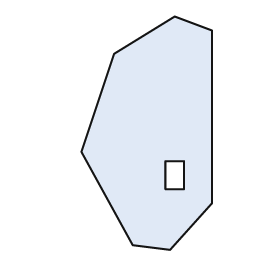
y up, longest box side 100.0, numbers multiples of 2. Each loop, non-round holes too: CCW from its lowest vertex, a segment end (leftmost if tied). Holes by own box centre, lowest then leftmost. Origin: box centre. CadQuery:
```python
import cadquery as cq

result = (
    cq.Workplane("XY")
    .moveTo(10.0, -50.0)
    .lineTo(28.0, -30.0)
    .lineTo(28.0, 44.0)
    .lineTo(12.0, 50.0)
    .lineTo(-14.0, 34.0)
    .lineTo(-28.0, -8.0)
    .lineTo(-6.0, -48.0)
    .close()
    .moveTo(8.0, -24.0)
    .lineTo(16.0, -24.0)
    .lineTo(16.0, -12.0)
    .lineTo(8.0, -12.0)
    .close()
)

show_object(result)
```